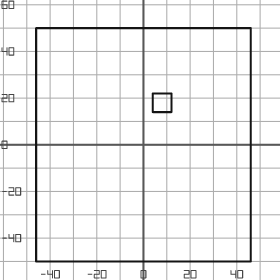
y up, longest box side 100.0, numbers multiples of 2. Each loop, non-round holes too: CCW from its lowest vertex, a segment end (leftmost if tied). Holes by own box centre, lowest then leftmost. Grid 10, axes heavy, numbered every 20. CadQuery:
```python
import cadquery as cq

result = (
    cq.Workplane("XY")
    .moveTo(-46.0, -50.0)
    .lineTo(46.0, -50.0)
    .lineTo(46.0, 50.0)
    .lineTo(-46.0, 50.0)
    .close()
    .moveTo(4.0, 14.0)
    .lineTo(12.0, 14.0)
    .lineTo(12.0, 22.0)
    .lineTo(4.0, 22.0)
    .close()
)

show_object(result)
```